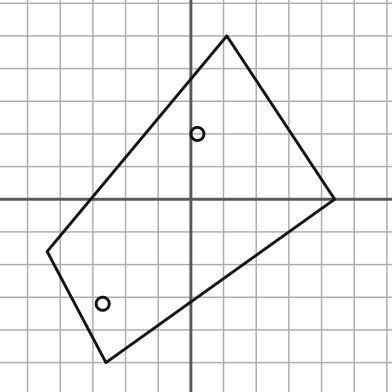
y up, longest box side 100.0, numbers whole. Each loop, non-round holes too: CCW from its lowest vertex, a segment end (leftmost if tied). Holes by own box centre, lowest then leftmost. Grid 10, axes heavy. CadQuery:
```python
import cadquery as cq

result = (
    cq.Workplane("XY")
    .moveTo(-26.0, -50.0)
    .lineTo(44.0, 0.0)
    .lineTo(11.0, 50.0)
    .lineTo(-44.0, -16.0)
    .close()
    .moveTo(-27.0, -32.0)
    .circle(2.0)
    .moveTo(2.0, 20.0)
    .circle(2.0)
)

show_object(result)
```